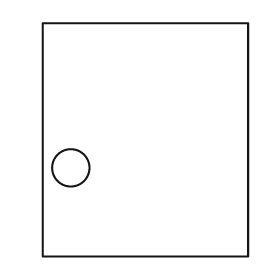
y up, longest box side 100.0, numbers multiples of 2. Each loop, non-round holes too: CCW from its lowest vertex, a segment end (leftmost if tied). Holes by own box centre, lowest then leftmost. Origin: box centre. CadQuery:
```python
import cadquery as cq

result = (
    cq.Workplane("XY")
    .moveTo(-44.0, -50.0)
    .lineTo(44.0, -50.0)
    .lineTo(44.0, 50.0)
    .lineTo(-44.0, 50.0)
    .close()
    .moveTo(-32.0, -12.0)
    .circle(8.0)
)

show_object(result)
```